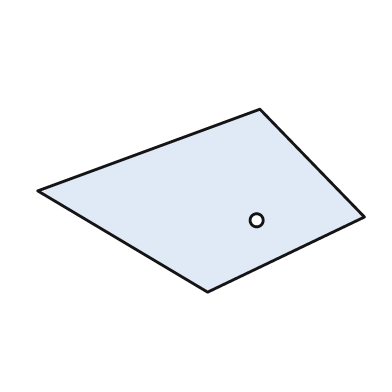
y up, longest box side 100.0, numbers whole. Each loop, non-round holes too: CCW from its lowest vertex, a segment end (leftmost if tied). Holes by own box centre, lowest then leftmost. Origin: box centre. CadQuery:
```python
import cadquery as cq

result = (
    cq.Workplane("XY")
    .moveTo(2.0, -28.0)
    .lineTo(50.0, -5.0)
    .lineTo(18.0, 28.0)
    .lineTo(-50.0, 3.0)
    .close()
    .moveTo(17.0, -6.0)
    .circle(2.0)
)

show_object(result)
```